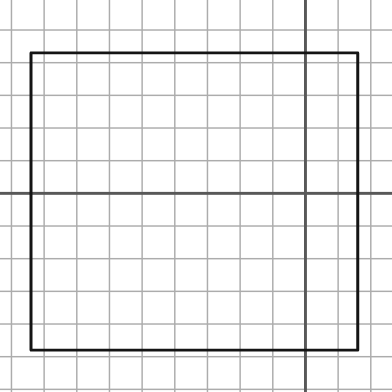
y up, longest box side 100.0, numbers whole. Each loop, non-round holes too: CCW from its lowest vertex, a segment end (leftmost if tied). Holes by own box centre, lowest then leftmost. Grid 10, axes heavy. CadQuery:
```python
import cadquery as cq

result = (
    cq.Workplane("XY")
    .moveTo(-84.0, -48.0)
    .lineTo(16.0, -48.0)
    .lineTo(16.0, 43.0)
    .lineTo(-84.0, 43.0)
    .close()
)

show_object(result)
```